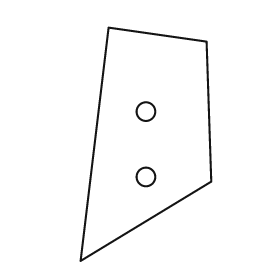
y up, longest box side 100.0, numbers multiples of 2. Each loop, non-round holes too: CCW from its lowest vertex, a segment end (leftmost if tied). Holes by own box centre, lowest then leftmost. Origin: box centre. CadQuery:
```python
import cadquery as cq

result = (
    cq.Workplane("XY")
    .moveTo(-28.0, -50.0)
    .lineTo(28.0, -16.0)
    .lineTo(26.0, 44.0)
    .lineTo(-16.0, 50.0)
    .close()
    .moveTo(0.0, -14.0)
    .circle(4.0)
    .moveTo(0.0, 14.0)
    .circle(4.0)
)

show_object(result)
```